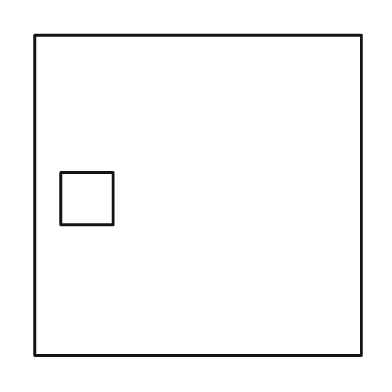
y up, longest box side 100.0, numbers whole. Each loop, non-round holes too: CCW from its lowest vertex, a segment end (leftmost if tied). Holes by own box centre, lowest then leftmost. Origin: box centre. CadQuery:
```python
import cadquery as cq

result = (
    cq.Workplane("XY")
    .moveTo(-50.0, -49.0)
    .lineTo(50.0, -49.0)
    .lineTo(50.0, 49.0)
    .lineTo(-50.0, 49.0)
    .close()
    .moveTo(-42.0, -9.0)
    .lineTo(-26.0, -9.0)
    .lineTo(-26.0, 7.0)
    .lineTo(-42.0, 7.0)
    .close()
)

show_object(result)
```